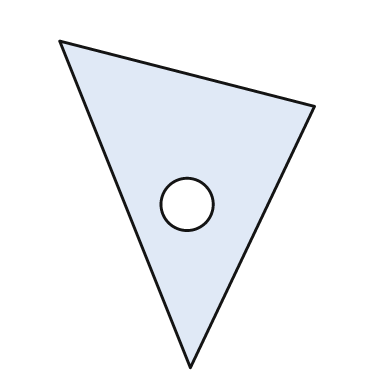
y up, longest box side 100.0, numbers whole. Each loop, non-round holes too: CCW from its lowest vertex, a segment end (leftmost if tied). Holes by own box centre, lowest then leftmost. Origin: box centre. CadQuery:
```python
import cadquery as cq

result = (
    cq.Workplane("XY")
    .moveTo(1.0, -50.0)
    .lineTo(39.0, 30.0)
    .lineTo(-39.0, 50.0)
    .close()
    .moveTo(0.0, 0.0)
    .circle(8.0)
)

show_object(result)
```